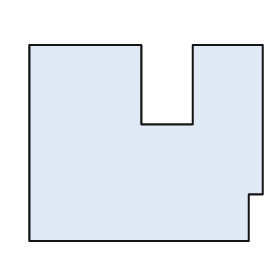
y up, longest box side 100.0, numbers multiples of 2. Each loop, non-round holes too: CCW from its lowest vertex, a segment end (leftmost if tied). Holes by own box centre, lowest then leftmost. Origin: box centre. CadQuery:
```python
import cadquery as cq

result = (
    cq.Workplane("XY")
    .moveTo(-50.0, -42.0)
    .lineTo(44.0, -42.0)
    .lineTo(44.0, -22.0)
    .lineTo(50.0, -22.0)
    .lineTo(50.0, 42.0)
    .lineTo(20.0, 42.0)
    .lineTo(20.0, 8.0)
    .lineTo(-2.0, 8.0)
    .lineTo(-2.0, 42.0)
    .lineTo(-50.0, 42.0)
    .close()
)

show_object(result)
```